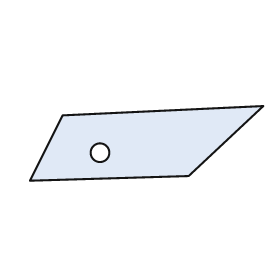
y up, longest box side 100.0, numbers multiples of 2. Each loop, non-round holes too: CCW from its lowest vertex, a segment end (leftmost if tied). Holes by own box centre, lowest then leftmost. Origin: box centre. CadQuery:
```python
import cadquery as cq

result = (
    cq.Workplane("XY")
    .moveTo(-50.0, -16.0)
    .lineTo(18.0, -14.0)
    .lineTo(50.0, 16.0)
    .lineTo(-36.0, 12.0)
    .close()
    .moveTo(-20.0, -4.0)
    .circle(4.0)
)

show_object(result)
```